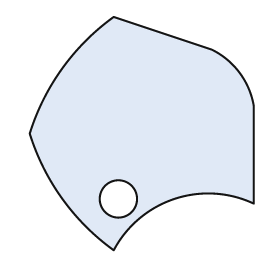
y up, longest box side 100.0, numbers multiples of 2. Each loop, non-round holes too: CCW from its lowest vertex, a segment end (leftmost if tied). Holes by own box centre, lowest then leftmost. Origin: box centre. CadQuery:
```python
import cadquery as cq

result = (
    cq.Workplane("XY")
    .moveTo(-12.0, -50.0)
    .threePointArc((14.0, -28.0), (48.0, -30.0))
    .lineTo(48.0, 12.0)
    .threePointArc((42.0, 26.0), (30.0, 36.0))
    .lineTo(-12.0, 50.0)
    .threePointArc((-34.0, 28.0), (-48.0, 0.0))
    .threePointArc((-34.0, -28.0), (-12.0, -50.0))
    .close()
    .moveTo(-10.0, -28.0)
    .circle(8.0)
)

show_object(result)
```